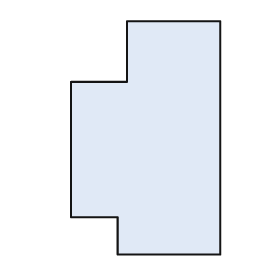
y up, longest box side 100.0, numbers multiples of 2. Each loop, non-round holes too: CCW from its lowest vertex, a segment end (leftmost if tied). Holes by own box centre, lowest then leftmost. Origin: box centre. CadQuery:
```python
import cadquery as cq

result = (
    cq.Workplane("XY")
    .moveTo(-12.0, -50.0)
    .lineTo(32.0, -50.0)
    .lineTo(32.0, 50.0)
    .lineTo(-8.0, 50.0)
    .lineTo(-8.0, 24.0)
    .lineTo(-32.0, 24.0)
    .lineTo(-32.0, -34.0)
    .lineTo(-12.0, -34.0)
    .close()
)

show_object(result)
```